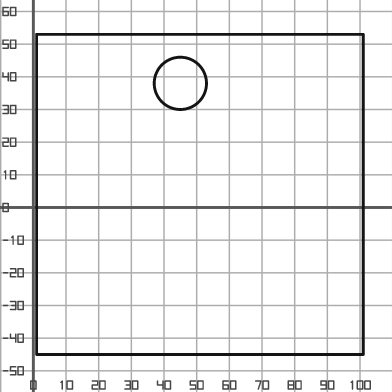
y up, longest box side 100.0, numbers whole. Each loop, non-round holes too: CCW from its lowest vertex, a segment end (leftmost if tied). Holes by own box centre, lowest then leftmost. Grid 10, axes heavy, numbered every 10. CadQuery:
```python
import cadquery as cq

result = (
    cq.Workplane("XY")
    .moveTo(1.0, -45.0)
    .lineTo(101.0, -45.0)
    .lineTo(101.0, 53.0)
    .lineTo(1.0, 53.0)
    .close()
    .moveTo(45.0, 38.0)
    .circle(8.0)
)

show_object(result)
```